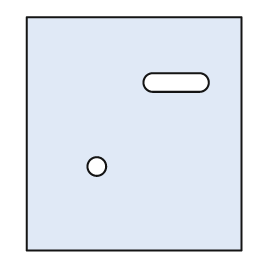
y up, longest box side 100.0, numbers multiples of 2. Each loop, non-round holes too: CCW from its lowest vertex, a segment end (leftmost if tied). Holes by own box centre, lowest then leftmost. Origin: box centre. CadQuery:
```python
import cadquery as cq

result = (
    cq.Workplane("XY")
    .moveTo(-46.0, -50.0)
    .lineTo(46.0, -50.0)
    .lineTo(46.0, 50.0)
    .lineTo(-46.0, 50.0)
    .close()
    .moveTo(-16.0, -14.0)
    .circle(4.0)
    .moveTo(8.0, 18.0)
    .lineTo(28.0, 18.0)
    .threePointArc((32.0, 22.0), (28.0, 26.0))
    .lineTo(8.0, 26.0)
    .threePointArc((4.0, 22.0), (8.0, 18.0))
    .close()
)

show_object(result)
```